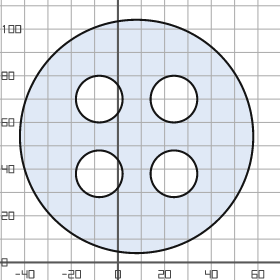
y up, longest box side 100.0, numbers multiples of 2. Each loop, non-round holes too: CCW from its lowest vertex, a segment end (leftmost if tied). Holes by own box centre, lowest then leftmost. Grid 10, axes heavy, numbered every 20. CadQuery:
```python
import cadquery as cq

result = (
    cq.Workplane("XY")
    .moveTo(8.0, 54.0)
    .circle(50.0)
    .moveTo(-8.0, 38.0)
    .circle(10.0)
    .moveTo(24.0, 38.0)
    .circle(10.0)
    .moveTo(-8.0, 70.0)
    .circle(10.0)
    .moveTo(24.0, 70.0)
    .circle(10.0)
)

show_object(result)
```